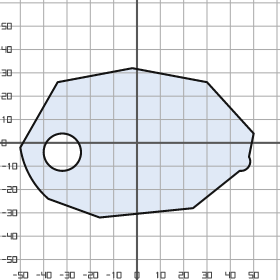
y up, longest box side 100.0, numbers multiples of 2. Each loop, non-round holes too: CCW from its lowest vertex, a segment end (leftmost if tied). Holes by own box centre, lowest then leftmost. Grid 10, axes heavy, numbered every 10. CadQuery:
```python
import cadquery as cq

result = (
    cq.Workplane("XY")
    .moveTo(-16.0, -32.0)
    .lineTo(24.0, -28.0)
    .lineTo(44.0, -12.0)
    .threePointArc((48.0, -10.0), (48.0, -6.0))
    .lineTo(50.0, 4.0)
    .lineTo(30.0, 26.0)
    .lineTo(-2.0, 32.0)
    .lineTo(-34.0, 26.0)
    .lineTo(-50.0, -2.0)
    .threePointArc((-46.0, -14.0), (-38.0, -24.0))
    .close()
    .moveTo(-32.0, -4.0)
    .circle(8.0)
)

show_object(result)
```